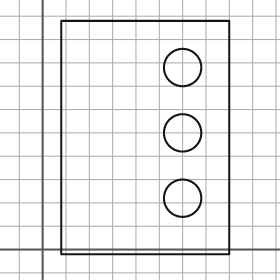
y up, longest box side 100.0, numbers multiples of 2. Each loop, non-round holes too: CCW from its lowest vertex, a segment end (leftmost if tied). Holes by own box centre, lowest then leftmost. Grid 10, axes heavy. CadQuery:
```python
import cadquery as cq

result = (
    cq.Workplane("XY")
    .moveTo(8.0, -2.0)
    .lineTo(80.0, -2.0)
    .lineTo(80.0, 98.0)
    .lineTo(8.0, 98.0)
    .close()
    .moveTo(60.0, 22.0)
    .circle(8.0)
    .moveTo(60.0, 50.0)
    .circle(8.0)
    .moveTo(60.0, 78.0)
    .circle(8.0)
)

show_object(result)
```